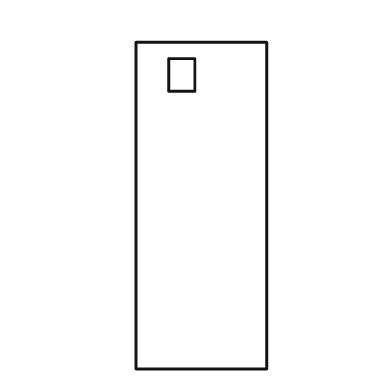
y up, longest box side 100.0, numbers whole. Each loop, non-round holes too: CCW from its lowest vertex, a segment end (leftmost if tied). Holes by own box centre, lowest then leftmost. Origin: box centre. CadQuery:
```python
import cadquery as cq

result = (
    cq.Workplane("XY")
    .moveTo(-20.0, -50.0)
    .lineTo(20.0, -50.0)
    .lineTo(20.0, 50.0)
    .lineTo(-20.0, 50.0)
    .close()
    .moveTo(-10.0, 35.0)
    .lineTo(-2.0, 35.0)
    .lineTo(-2.0, 45.0)
    .lineTo(-10.0, 45.0)
    .close()
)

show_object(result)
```